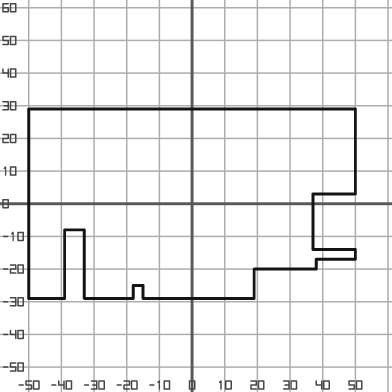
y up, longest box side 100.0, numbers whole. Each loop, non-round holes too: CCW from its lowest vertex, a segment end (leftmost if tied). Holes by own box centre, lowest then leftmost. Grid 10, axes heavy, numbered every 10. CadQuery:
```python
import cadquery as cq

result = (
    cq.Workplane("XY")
    .moveTo(-50.0, -29.0)
    .lineTo(-39.0, -29.0)
    .lineTo(-39.0, -8.0)
    .lineTo(-33.0, -8.0)
    .lineTo(-33.0, -29.0)
    .lineTo(-18.0, -29.0)
    .lineTo(-18.0, -25.0)
    .lineTo(-15.0, -25.0)
    .lineTo(-15.0, -29.0)
    .lineTo(19.0, -29.0)
    .lineTo(19.0, -20.0)
    .lineTo(38.0, -20.0)
    .lineTo(38.0, -17.0)
    .lineTo(50.0, -17.0)
    .lineTo(50.0, -14.0)
    .lineTo(37.0, -14.0)
    .lineTo(37.0, 3.0)
    .lineTo(50.0, 3.0)
    .lineTo(50.0, 29.0)
    .lineTo(-50.0, 29.0)
    .close()
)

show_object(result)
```